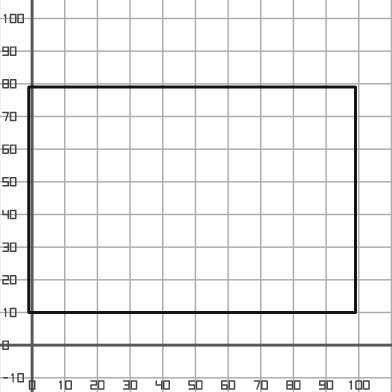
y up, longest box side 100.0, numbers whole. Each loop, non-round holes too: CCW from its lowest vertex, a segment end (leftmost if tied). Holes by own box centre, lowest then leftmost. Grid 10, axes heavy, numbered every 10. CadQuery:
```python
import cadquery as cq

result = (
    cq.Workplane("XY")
    .moveTo(-1.0, 10.0)
    .lineTo(99.0, 10.0)
    .lineTo(99.0, 79.0)
    .lineTo(-1.0, 79.0)
    .close()
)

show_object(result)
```